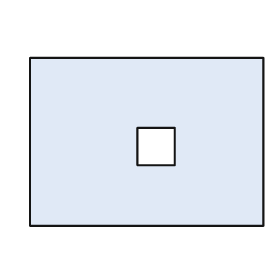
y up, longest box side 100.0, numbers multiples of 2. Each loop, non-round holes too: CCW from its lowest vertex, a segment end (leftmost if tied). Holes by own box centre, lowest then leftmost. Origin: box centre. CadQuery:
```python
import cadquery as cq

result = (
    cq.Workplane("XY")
    .moveTo(-50.0, -36.0)
    .lineTo(50.0, -36.0)
    .lineTo(50.0, 36.0)
    .lineTo(-50.0, 36.0)
    .close()
    .moveTo(-4.0, -10.0)
    .lineTo(12.0, -10.0)
    .lineTo(12.0, 6.0)
    .lineTo(-4.0, 6.0)
    .close()
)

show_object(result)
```